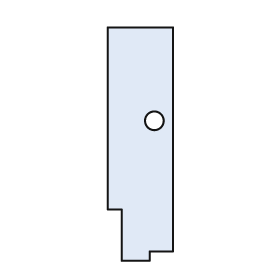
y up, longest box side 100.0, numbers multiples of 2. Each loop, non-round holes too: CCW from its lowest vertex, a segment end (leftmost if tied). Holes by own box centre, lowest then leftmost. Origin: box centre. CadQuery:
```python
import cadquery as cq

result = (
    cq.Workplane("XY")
    .moveTo(-8.0, -50.0)
    .lineTo(4.0, -50.0)
    .lineTo(4.0, -46.0)
    .lineTo(14.0, -46.0)
    .lineTo(14.0, 50.0)
    .lineTo(-14.0, 50.0)
    .lineTo(-14.0, -28.0)
    .lineTo(-8.0, -28.0)
    .close()
    .moveTo(6.0, 10.0)
    .circle(4.0)
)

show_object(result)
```